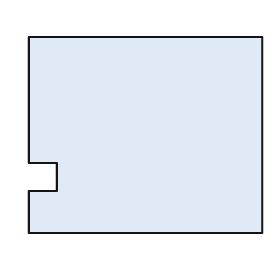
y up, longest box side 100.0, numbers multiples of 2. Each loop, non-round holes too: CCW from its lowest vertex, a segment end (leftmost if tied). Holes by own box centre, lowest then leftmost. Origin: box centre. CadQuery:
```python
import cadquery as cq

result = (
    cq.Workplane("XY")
    .moveTo(-50.0, -42.0)
    .lineTo(50.0, -42.0)
    .lineTo(50.0, 42.0)
    .lineTo(-50.0, 42.0)
    .lineTo(-50.0, -12.0)
    .lineTo(-38.0, -12.0)
    .lineTo(-38.0, -24.0)
    .lineTo(-50.0, -24.0)
    .close()
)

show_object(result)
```